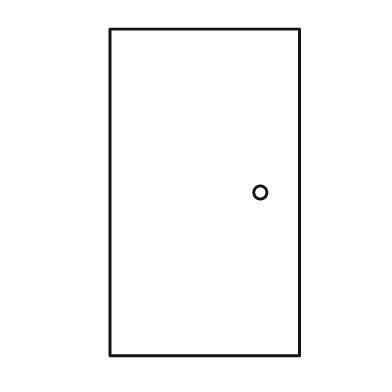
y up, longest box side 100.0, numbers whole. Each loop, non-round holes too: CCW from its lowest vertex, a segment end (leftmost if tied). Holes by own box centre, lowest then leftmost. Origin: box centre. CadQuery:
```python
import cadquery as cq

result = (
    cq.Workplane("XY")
    .moveTo(-29.0, -50.0)
    .lineTo(29.0, -50.0)
    .lineTo(29.0, 50.0)
    .lineTo(-29.0, 50.0)
    .close()
    .moveTo(17.0, 0.0)
    .circle(2.0)
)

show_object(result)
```